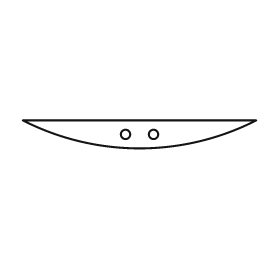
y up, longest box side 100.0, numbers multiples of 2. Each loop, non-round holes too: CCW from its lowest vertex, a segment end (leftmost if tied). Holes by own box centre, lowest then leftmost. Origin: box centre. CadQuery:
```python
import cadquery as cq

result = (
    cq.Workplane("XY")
    .moveTo(-50.0, 6.0)
    .threePointArc((0.0, -6.0), (50.0, 6.0))
    .close()
    .moveTo(-6.0, 0.0)
    .circle(2.0)
    .moveTo(6.0, 0.0)
    .circle(2.0)
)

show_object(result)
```